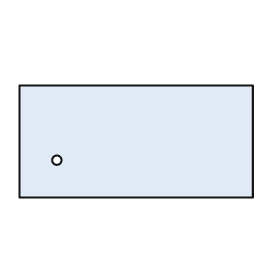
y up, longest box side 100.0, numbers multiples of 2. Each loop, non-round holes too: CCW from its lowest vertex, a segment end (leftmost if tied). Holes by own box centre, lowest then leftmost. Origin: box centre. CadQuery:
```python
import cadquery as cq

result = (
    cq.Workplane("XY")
    .moveTo(-50.0, -24.0)
    .lineTo(50.0, -24.0)
    .lineTo(50.0, 24.0)
    .lineTo(-50.0, 24.0)
    .close()
    .moveTo(-34.0, -8.0)
    .circle(2.0)
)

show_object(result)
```